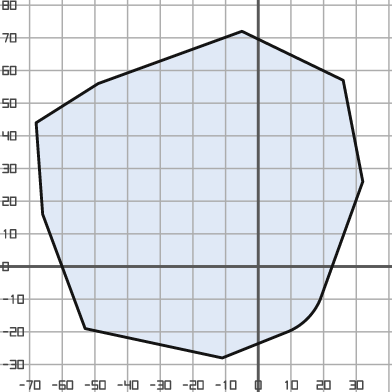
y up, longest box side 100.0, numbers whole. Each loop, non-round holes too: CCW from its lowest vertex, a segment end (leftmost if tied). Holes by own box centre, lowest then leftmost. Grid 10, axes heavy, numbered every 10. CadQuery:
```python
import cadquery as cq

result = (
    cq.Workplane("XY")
    .moveTo(-11.0, -28.0)
    .lineTo(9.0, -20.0)
    .threePointArc((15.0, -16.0), (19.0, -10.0))
    .lineTo(32.0, 26.0)
    .lineTo(26.0, 57.0)
    .lineTo(-5.0, 72.0)
    .lineTo(-49.0, 56.0)
    .lineTo(-68.0, 44.0)
    .lineTo(-66.0, 16.0)
    .lineTo(-53.0, -19.0)
    .close()
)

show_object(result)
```